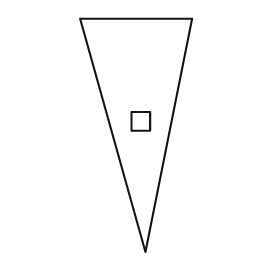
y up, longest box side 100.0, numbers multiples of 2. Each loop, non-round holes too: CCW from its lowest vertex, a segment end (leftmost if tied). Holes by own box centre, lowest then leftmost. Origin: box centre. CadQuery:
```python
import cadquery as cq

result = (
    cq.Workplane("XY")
    .moveTo(4.0, -50.0)
    .lineTo(24.0, 50.0)
    .lineTo(-24.0, 50.0)
    .close()
    .moveTo(-2.0, 2.0)
    .lineTo(6.0, 2.0)
    .lineTo(6.0, 10.0)
    .lineTo(-2.0, 10.0)
    .close()
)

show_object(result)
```